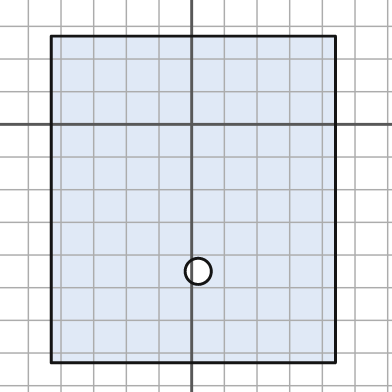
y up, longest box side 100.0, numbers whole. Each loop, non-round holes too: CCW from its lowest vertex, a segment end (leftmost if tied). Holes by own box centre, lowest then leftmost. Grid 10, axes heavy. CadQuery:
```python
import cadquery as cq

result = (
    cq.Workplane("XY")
    .moveTo(-43.0, -73.0)
    .lineTo(44.0, -73.0)
    .lineTo(44.0, 27.0)
    .lineTo(-43.0, 27.0)
    .close()
    .moveTo(2.0, -45.0)
    .circle(4.0)
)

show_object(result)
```